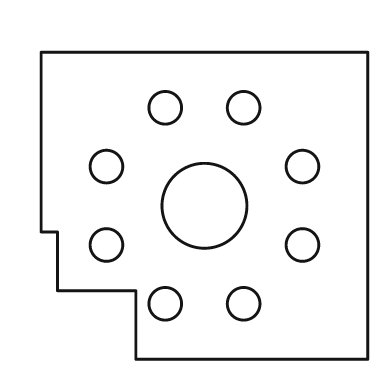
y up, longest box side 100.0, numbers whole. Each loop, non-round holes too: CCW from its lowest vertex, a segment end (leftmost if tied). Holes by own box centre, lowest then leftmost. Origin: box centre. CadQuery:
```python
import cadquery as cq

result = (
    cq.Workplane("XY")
    .moveTo(-21.0, -47.0)
    .lineTo(50.0, -47.0)
    .lineTo(50.0, 47.0)
    .lineTo(-50.0, 47.0)
    .lineTo(-50.0, -8.0)
    .lineTo(-45.0, -8.0)
    .lineTo(-45.0, -26.0)
    .lineTo(-21.0, -26.0)
    .close()
    .moveTo(-12.0, -30.0)
    .circle(5.0)
    .moveTo(12.0, -30.0)
    .circle(5.0)
    .moveTo(-30.0, -12.0)
    .circle(5.0)
    .moveTo(30.0, -12.0)
    .circle(5.0)
    .moveTo(0.0, 0.0)
    .circle(13.0)
    .moveTo(-30.0, 12.0)
    .circle(5.0)
    .moveTo(30.0, 12.0)
    .circle(5.0)
    .moveTo(-12.0, 30.0)
    .circle(5.0)
    .moveTo(12.0, 30.0)
    .circle(5.0)
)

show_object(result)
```